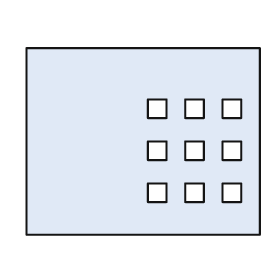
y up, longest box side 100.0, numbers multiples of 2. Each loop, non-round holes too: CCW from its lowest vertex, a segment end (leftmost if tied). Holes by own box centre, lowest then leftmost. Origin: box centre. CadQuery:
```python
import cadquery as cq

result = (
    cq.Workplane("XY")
    .moveTo(-50.0, -40.0)
    .lineTo(50.0, -40.0)
    .lineTo(50.0, 40.0)
    .lineTo(-50.0, 40.0)
    .close()
    .moveTo(2.0, -26.0)
    .lineTo(10.0, -26.0)
    .lineTo(10.0, -18.0)
    .lineTo(2.0, -18.0)
    .close()
    .moveTo(18.0, -26.0)
    .lineTo(26.0, -26.0)
    .lineTo(26.0, -18.0)
    .lineTo(18.0, -18.0)
    .close()
    .moveTo(34.0, -26.0)
    .lineTo(42.0, -26.0)
    .lineTo(42.0, -18.0)
    .lineTo(34.0, -18.0)
    .close()
    .moveTo(2.0, -8.0)
    .lineTo(10.0, -8.0)
    .lineTo(10.0, 0.0)
    .lineTo(2.0, 0.0)
    .close()
    .moveTo(18.0, -8.0)
    .lineTo(26.0, -8.0)
    .lineTo(26.0, 0.0)
    .lineTo(18.0, 0.0)
    .close()
    .moveTo(34.0, -8.0)
    .lineTo(42.0, -8.0)
    .lineTo(42.0, 0.0)
    .lineTo(34.0, 0.0)
    .close()
    .moveTo(2.0, 10.0)
    .lineTo(10.0, 10.0)
    .lineTo(10.0, 18.0)
    .lineTo(2.0, 18.0)
    .close()
    .moveTo(18.0, 10.0)
    .lineTo(26.0, 10.0)
    .lineTo(26.0, 18.0)
    .lineTo(18.0, 18.0)
    .close()
    .moveTo(34.0, 10.0)
    .lineTo(42.0, 10.0)
    .lineTo(42.0, 18.0)
    .lineTo(34.0, 18.0)
    .close()
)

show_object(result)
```